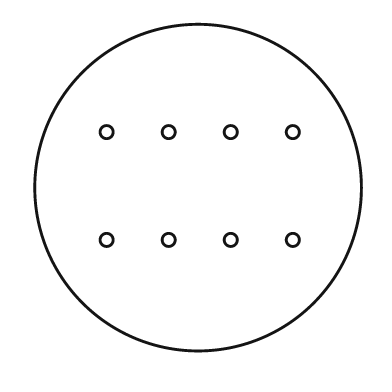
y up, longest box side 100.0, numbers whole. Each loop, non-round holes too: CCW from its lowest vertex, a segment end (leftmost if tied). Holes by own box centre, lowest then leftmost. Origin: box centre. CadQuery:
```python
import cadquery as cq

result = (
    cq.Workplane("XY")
    .moveTo(0.0, 0.0)
    .circle(50.0)
    .moveTo(-28.0, -16.0)
    .circle(2.0)
    .moveTo(-9.0, -16.0)
    .circle(2.0)
    .moveTo(10.0, -16.0)
    .circle(2.0)
    .moveTo(29.0, -16.0)
    .circle(2.0)
    .moveTo(-28.0, 17.0)
    .circle(2.0)
    .moveTo(-9.0, 17.0)
    .circle(2.0)
    .moveTo(10.0, 17.0)
    .circle(2.0)
    .moveTo(29.0, 17.0)
    .circle(2.0)
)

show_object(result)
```